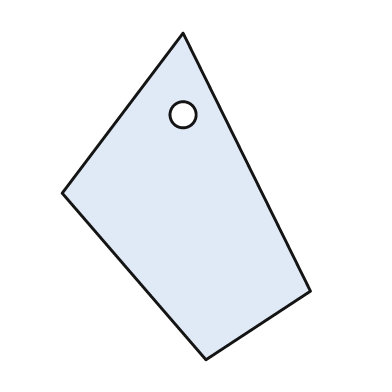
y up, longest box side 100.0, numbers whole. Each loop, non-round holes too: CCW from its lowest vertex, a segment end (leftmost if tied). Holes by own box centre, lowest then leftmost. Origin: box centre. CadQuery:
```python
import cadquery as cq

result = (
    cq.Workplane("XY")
    .moveTo(6.0, -50.0)
    .lineTo(38.0, -29.0)
    .lineTo(-1.0, 50.0)
    .lineTo(-38.0, 1.0)
    .close()
    .moveTo(-1.0, 25.0)
    .circle(4.0)
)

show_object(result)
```